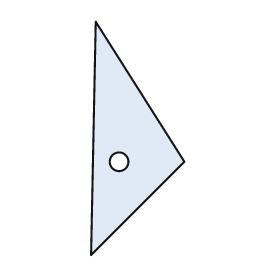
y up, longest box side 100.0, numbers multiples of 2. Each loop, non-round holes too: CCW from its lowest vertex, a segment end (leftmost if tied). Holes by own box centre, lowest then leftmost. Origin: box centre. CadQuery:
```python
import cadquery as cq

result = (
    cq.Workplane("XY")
    .moveTo(-20.0, -50.0)
    .lineTo(20.0, -10.0)
    .lineTo(-18.0, 50.0)
    .close()
    .moveTo(-8.0, -10.0)
    .circle(4.0)
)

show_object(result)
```